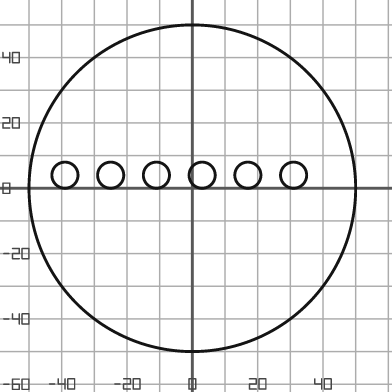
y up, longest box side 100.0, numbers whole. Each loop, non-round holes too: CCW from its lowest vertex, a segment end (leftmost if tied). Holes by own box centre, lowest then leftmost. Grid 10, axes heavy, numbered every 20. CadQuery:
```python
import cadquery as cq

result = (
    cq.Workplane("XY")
    .moveTo(0.0, 0.0)
    .circle(50.0)
    .moveTo(-39.0, 4.0)
    .circle(4.0)
    .moveTo(-25.0, 4.0)
    .circle(4.0)
    .moveTo(-11.0, 4.0)
    .circle(4.0)
    .moveTo(3.0, 4.0)
    .circle(4.0)
    .moveTo(17.0, 4.0)
    .circle(4.0)
    .moveTo(31.0, 4.0)
    .circle(4.0)
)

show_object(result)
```